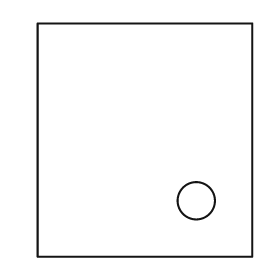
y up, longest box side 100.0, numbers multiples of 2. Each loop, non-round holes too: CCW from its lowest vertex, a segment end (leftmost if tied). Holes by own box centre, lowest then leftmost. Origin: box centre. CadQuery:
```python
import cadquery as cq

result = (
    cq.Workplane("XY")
    .moveTo(-46.0, -50.0)
    .lineTo(46.0, -50.0)
    .lineTo(46.0, 50.0)
    .lineTo(-46.0, 50.0)
    .close()
    .moveTo(22.0, -26.0)
    .circle(8.0)
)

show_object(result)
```